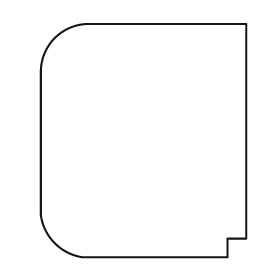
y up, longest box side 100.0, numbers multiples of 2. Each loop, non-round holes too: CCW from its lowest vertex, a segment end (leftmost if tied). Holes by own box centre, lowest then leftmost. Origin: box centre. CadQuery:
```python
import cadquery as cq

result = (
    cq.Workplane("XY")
    .moveTo(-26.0, -50.0)
    .lineTo(36.0, -50.0)
    .lineTo(36.0, -42.0)
    .lineTo(44.0, -42.0)
    .lineTo(44.0, 50.0)
    .lineTo(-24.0, 50.0)
    .threePointArc((-38.0, 44.0), (-44.0, 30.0))
    .lineTo(-44.0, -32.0)
    .threePointArc((-38.0, -44.0), (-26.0, -50.0))
    .close()
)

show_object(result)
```